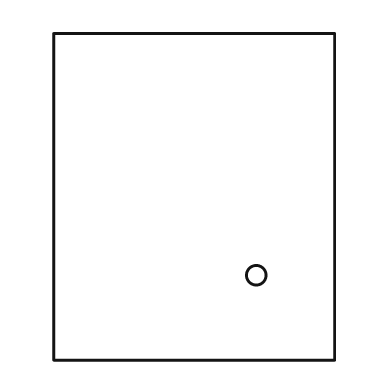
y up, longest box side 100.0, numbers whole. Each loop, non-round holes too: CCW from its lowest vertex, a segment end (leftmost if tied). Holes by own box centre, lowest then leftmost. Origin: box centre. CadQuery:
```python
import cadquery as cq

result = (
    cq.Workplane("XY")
    .moveTo(-43.0, -50.0)
    .lineTo(43.0, -50.0)
    .lineTo(43.0, 50.0)
    .lineTo(-43.0, 50.0)
    .close()
    .moveTo(19.0, -24.0)
    .circle(3.0)
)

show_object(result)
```